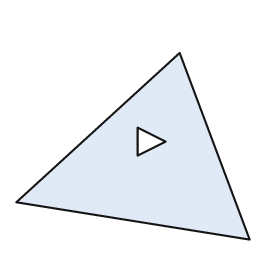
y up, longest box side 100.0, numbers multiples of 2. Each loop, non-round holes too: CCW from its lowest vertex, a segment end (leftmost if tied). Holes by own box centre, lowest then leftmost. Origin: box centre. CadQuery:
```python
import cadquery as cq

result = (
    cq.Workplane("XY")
    .moveTo(50.0, -40.0)
    .lineTo(20.0, 40.0)
    .lineTo(-50.0, -24.0)
    .close()
    .moveTo(2.0, -4.0)
    .lineTo(14.0, 2.0)
    .lineTo(2.0, 8.0)
    .close()
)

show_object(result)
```